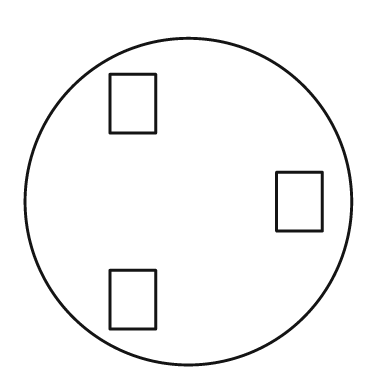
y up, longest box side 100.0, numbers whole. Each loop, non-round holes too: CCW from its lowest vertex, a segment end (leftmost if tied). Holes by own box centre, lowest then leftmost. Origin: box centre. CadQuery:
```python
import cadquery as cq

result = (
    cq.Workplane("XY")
    .moveTo(0.0, 0.0)
    .circle(50.0)
    .moveTo(-24.0, -39.0)
    .lineTo(-10.0, -39.0)
    .lineTo(-10.0, -21.0)
    .lineTo(-24.0, -21.0)
    .close()
    .moveTo(27.0, -9.0)
    .lineTo(41.0, -9.0)
    .lineTo(41.0, 9.0)
    .lineTo(27.0, 9.0)
    .close()
    .moveTo(-24.0, 21.0)
    .lineTo(-10.0, 21.0)
    .lineTo(-10.0, 39.0)
    .lineTo(-24.0, 39.0)
    .close()
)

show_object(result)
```